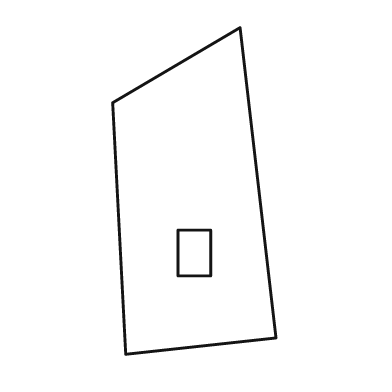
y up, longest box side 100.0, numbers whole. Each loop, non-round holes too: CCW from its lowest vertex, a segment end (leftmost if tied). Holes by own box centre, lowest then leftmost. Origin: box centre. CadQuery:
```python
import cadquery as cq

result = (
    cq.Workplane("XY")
    .moveTo(-21.0, -50.0)
    .lineTo(25.0, -45.0)
    .lineTo(14.0, 50.0)
    .lineTo(-25.0, 27.0)
    .close()
    .moveTo(-5.0, -26.0)
    .lineTo(5.0, -26.0)
    .lineTo(5.0, -12.0)
    .lineTo(-5.0, -12.0)
    .close()
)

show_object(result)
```